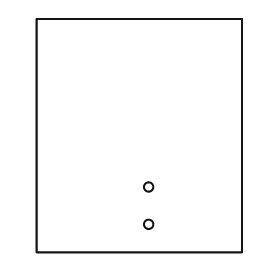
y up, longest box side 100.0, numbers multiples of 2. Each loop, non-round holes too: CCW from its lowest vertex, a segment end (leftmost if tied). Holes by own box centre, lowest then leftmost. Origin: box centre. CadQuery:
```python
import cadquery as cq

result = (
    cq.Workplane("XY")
    .moveTo(-44.0, -50.0)
    .lineTo(44.0, -50.0)
    .lineTo(44.0, 50.0)
    .lineTo(-44.0, 50.0)
    .close()
    .moveTo(4.0, -38.0)
    .circle(2.0)
    .moveTo(4.0, -22.0)
    .circle(2.0)
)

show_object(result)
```